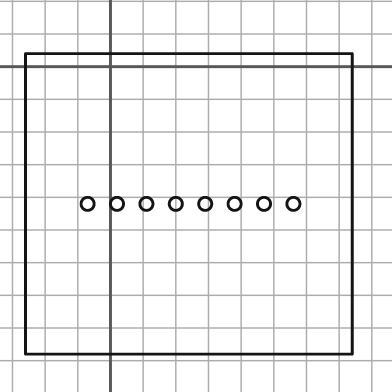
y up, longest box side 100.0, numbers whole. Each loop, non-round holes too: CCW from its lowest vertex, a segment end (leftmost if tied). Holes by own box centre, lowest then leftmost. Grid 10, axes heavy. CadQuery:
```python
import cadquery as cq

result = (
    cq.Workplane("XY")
    .moveTo(-26.0, -88.0)
    .lineTo(74.0, -88.0)
    .lineTo(74.0, 4.0)
    .lineTo(-26.0, 4.0)
    .close()
    .moveTo(-7.0, -42.0)
    .circle(2.0)
    .moveTo(2.0, -42.0)
    .circle(2.0)
    .moveTo(11.0, -42.0)
    .circle(2.0)
    .moveTo(20.0, -42.0)
    .circle(2.0)
    .moveTo(29.0, -42.0)
    .circle(2.0)
    .moveTo(38.0, -42.0)
    .circle(2.0)
    .moveTo(47.0, -42.0)
    .circle(2.0)
    .moveTo(56.0, -42.0)
    .circle(2.0)
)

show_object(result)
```